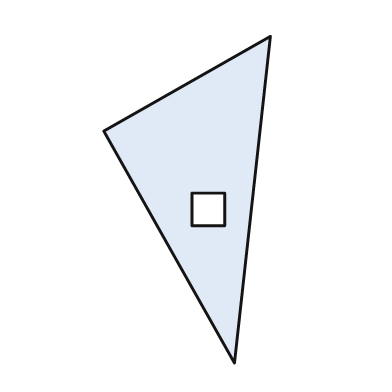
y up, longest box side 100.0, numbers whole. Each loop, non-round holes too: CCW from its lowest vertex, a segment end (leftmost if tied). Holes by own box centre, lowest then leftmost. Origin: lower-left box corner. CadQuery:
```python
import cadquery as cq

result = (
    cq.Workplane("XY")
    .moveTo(40.0, 0.0)
    .lineTo(51.0, 100.0)
    .lineTo(0.0, 71.0)
    .close()
    .moveTo(27.0, 42.0)
    .lineTo(37.0, 42.0)
    .lineTo(37.0, 52.0)
    .lineTo(27.0, 52.0)
    .close()
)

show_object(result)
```